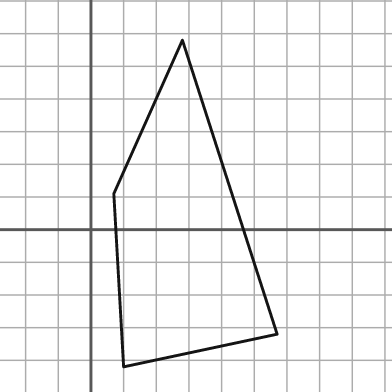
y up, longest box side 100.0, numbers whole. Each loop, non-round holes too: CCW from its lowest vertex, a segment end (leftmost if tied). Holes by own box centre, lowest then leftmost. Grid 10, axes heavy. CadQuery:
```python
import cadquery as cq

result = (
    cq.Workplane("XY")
    .moveTo(10.0, -42.0)
    .lineTo(57.0, -32.0)
    .lineTo(28.0, 58.0)
    .lineTo(7.0, 11.0)
    .close()
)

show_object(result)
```